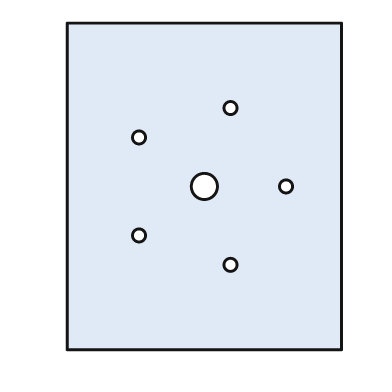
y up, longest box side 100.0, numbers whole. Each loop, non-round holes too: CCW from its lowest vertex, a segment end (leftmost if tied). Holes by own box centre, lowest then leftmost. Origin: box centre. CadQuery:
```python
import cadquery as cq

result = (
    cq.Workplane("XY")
    .moveTo(-42.0, -50.0)
    .lineTo(42.0, -50.0)
    .lineTo(42.0, 50.0)
    .lineTo(-42.0, 50.0)
    .close()
    .moveTo(8.0, -24.0)
    .circle(2.0)
    .moveTo(-20.0, -15.0)
    .circle(2.0)
    .moveTo(0.0, 0.0)
    .circle(4.0)
    .moveTo(25.0, 0.0)
    .circle(2.0)
    .moveTo(-20.0, 15.0)
    .circle(2.0)
    .moveTo(8.0, 24.0)
    .circle(2.0)
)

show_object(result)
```